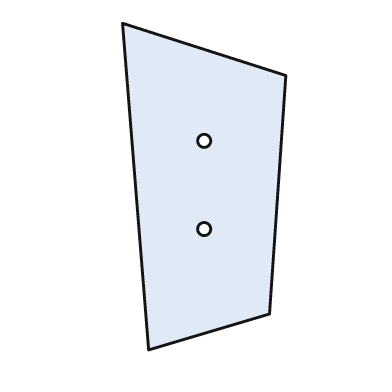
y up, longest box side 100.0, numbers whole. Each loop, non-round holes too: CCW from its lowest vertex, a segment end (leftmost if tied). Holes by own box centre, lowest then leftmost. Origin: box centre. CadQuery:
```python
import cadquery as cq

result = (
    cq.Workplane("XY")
    .moveTo(-17.0, -50.0)
    .lineTo(20.0, -39.0)
    .lineTo(25.0, 34.0)
    .lineTo(-25.0, 50.0)
    .close()
    .moveTo(0.0, -13.0)
    .circle(2.0)
    .moveTo(0.0, 14.0)
    .circle(2.0)
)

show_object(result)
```